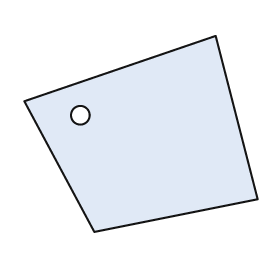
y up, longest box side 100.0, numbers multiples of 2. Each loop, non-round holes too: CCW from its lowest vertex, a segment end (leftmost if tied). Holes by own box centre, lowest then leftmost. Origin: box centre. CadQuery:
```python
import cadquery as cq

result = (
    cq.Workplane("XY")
    .moveTo(-20.0, -42.0)
    .lineTo(50.0, -28.0)
    .lineTo(32.0, 42.0)
    .lineTo(-50.0, 14.0)
    .close()
    .moveTo(-26.0, 8.0)
    .circle(4.0)
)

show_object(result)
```